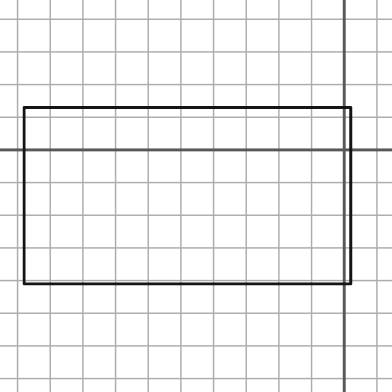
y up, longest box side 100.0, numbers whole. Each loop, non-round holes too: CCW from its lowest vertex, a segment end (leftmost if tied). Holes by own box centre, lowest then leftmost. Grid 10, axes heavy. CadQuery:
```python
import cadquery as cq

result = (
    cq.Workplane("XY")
    .moveTo(-98.0, -41.0)
    .lineTo(2.0, -41.0)
    .lineTo(2.0, 13.0)
    .lineTo(-98.0, 13.0)
    .close()
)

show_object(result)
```